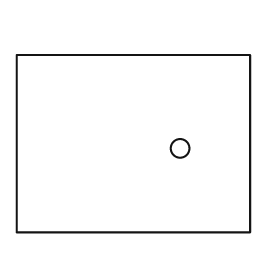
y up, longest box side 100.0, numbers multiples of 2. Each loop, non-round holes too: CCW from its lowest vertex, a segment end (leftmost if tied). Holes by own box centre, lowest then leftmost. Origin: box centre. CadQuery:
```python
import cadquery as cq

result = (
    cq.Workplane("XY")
    .moveTo(-50.0, -38.0)
    .lineTo(50.0, -38.0)
    .lineTo(50.0, 38.0)
    .lineTo(-50.0, 38.0)
    .close()
    .moveTo(20.0, -2.0)
    .circle(4.0)
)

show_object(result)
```